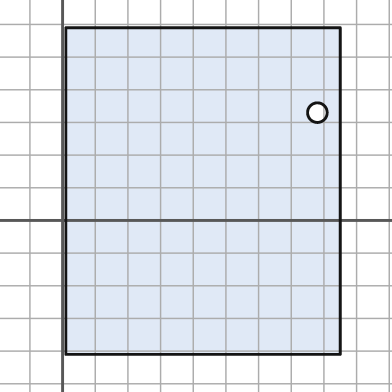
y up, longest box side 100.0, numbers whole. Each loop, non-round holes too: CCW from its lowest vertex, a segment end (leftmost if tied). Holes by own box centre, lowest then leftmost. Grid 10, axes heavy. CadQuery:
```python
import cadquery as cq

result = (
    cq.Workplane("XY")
    .moveTo(1.0, -41.0)
    .lineTo(85.0, -41.0)
    .lineTo(85.0, 59.0)
    .lineTo(1.0, 59.0)
    .close()
    .moveTo(78.0, 33.0)
    .circle(3.0)
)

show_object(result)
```